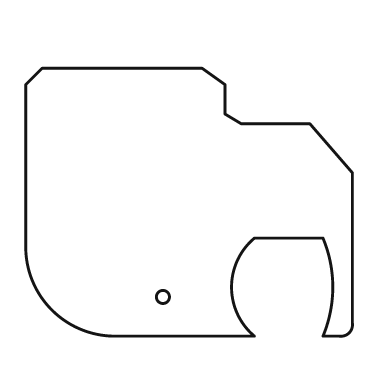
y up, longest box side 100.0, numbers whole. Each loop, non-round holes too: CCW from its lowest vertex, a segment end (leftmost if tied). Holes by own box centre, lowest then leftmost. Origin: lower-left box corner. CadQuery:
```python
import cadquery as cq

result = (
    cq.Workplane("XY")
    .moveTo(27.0, 0.0)
    .lineTo(70.0, 0.0)
    .threePointArc((63.0, 15.0), (70.0, 30.0))
    .lineTo(91.0, 30.0)
    .threePointArc((94.0, 15.0), (91.0, 0.0))
    .lineTo(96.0, 0.0)
    .threePointArc((99.0, 1.0), (100.0, 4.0))
    .lineTo(100.0, 50.0)
    .lineTo(87.0, 65.0)
    .lineTo(66.0, 65.0)
    .lineTo(61.0, 68.0)
    .lineTo(61.0, 77.0)
    .lineTo(54.0, 82.0)
    .lineTo(5.0, 82.0)
    .lineTo(0.0, 77.0)
    .lineTo(0.0, 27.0)
    .threePointArc((8.0, 8.0), (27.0, 0.0))
    .close()
    .moveTo(42.0, 12.0)
    .circle(2.0)
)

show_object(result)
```